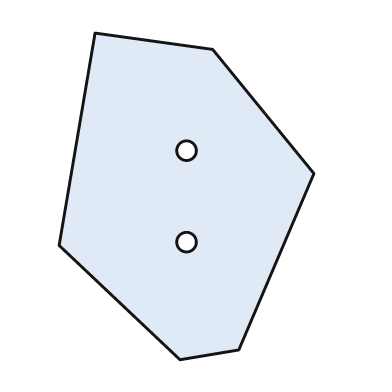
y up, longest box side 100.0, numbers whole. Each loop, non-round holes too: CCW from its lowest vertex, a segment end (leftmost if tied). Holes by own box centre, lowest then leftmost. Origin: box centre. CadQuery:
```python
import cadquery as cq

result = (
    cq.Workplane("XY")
    .moveTo(-2.0, -50.0)
    .lineTo(16.0, -47.0)
    .lineTo(39.0, 7.0)
    .lineTo(8.0, 45.0)
    .lineTo(-28.0, 50.0)
    .lineTo(-39.0, -15.0)
    .close()
    .moveTo(0.0, -14.0)
    .circle(3.0)
    .moveTo(0.0, 14.0)
    .circle(3.0)
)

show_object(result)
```